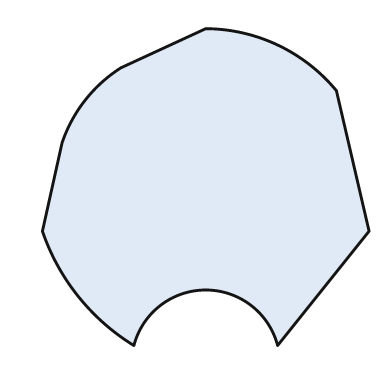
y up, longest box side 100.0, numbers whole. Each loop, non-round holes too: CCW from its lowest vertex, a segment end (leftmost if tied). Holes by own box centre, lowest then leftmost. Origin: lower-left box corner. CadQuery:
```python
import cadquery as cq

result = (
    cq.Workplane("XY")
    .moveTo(28.0, 0.0)
    .threePointArc((50.0, 17.0), (72.0, 0.0))
    .lineTo(100.0, 35.0)
    .lineTo(90.0, 78.0)
    .threePointArc((72.0, 92.0), (50.0, 97.0))
    .lineTo(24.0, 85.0)
    .threePointArc((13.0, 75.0), (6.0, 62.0))
    .lineTo(0.0, 35.0)
    .threePointArc((11.0, 15.0), (28.0, 0.0))
    .close()
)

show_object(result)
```